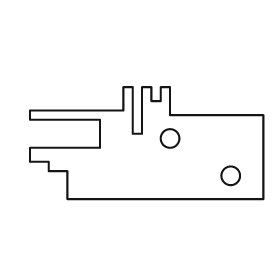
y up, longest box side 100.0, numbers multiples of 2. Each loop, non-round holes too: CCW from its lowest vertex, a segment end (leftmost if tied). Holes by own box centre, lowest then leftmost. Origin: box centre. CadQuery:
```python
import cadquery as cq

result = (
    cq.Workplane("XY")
    .moveTo(-34.0, -24.0)
    .lineTo(50.0, -24.0)
    .lineTo(50.0, 12.0)
    .lineTo(10.0, 12.0)
    .lineTo(10.0, 24.0)
    .lineTo(6.0, 24.0)
    .lineTo(6.0, 18.0)
    .lineTo(2.0, 18.0)
    .lineTo(2.0, 24.0)
    .lineTo(-2.0, 24.0)
    .lineTo(-2.0, 4.0)
    .lineTo(-6.0, 4.0)
    .lineTo(-6.0, 24.0)
    .lineTo(-10.0, 24.0)
    .lineTo(-10.0, 14.0)
    .lineTo(-50.0, 14.0)
    .lineTo(-50.0, 10.0)
    .lineTo(-20.0, 10.0)
    .lineTo(-20.0, -2.0)
    .lineTo(-50.0, -2.0)
    .lineTo(-50.0, -8.0)
    .lineTo(-42.0, -8.0)
    .lineTo(-42.0, -12.0)
    .lineTo(-34.0, -12.0)
    .close()
    .moveTo(36.0, -14.0)
    .circle(4.0)
    .moveTo(10.0, 2.0)
    .circle(4.0)
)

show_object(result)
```